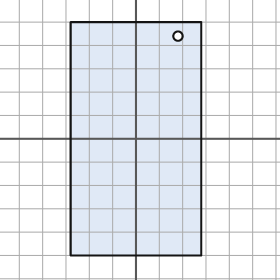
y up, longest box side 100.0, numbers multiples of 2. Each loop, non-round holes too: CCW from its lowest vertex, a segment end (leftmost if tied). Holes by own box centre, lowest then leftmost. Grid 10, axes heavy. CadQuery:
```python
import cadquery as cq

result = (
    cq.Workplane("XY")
    .moveTo(-28.0, -50.0)
    .lineTo(28.0, -50.0)
    .lineTo(28.0, 50.0)
    .lineTo(-28.0, 50.0)
    .close()
    .moveTo(18.0, 44.0)
    .circle(2.0)
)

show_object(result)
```